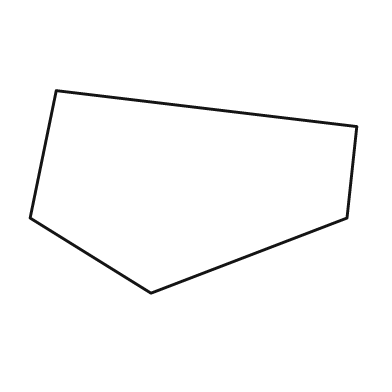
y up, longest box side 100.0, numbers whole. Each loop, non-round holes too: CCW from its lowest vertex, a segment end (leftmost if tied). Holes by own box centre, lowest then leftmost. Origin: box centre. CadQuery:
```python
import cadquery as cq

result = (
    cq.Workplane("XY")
    .moveTo(-13.0, -31.0)
    .lineTo(47.0, -8.0)
    .lineTo(50.0, 20.0)
    .lineTo(-42.0, 31.0)
    .lineTo(-50.0, -8.0)
    .close()
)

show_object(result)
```